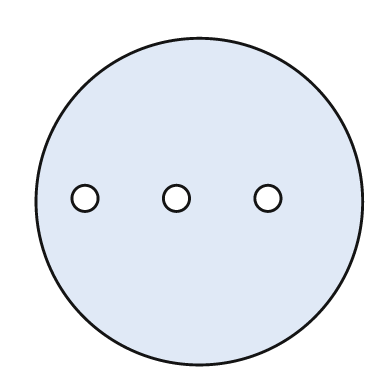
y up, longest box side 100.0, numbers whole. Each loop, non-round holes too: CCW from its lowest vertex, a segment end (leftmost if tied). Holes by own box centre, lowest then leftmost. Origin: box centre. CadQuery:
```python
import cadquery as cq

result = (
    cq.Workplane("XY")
    .moveTo(0.0, 0.0)
    .circle(50.0)
    .moveTo(-35.0, 1.0)
    .circle(4.0)
    .moveTo(-7.0, 1.0)
    .circle(4.0)
    .moveTo(21.0, 1.0)
    .circle(4.0)
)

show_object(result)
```